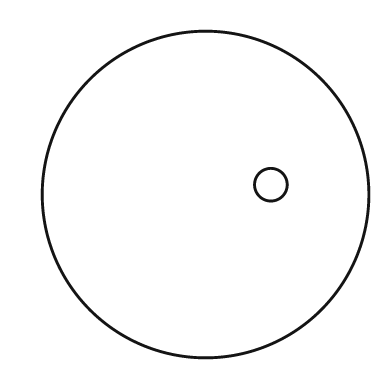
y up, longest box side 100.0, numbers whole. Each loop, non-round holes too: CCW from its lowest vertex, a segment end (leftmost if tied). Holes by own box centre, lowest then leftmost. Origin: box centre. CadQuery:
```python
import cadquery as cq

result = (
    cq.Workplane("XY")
    .moveTo(0.0, 0.0)
    .circle(50.0)
    .moveTo(20.0, 3.0)
    .circle(5.0)
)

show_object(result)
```